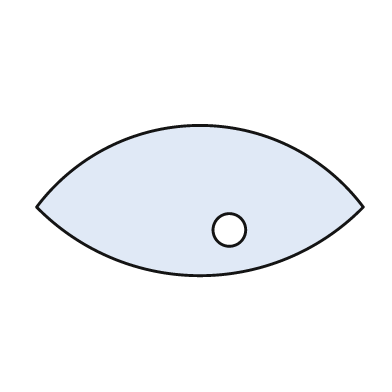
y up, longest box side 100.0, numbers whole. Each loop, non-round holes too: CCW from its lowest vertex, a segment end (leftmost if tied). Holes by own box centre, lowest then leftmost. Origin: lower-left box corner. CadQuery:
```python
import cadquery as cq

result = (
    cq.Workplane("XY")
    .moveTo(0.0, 21.0)
    .threePointArc((50.0, 0.0), (100.0, 21.0))
    .threePointArc((50.0, 46.0), (0.0, 21.0))
    .close()
    .moveTo(59.0, 14.0)
    .circle(5.0)
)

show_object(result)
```